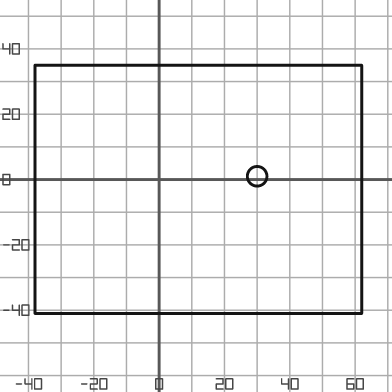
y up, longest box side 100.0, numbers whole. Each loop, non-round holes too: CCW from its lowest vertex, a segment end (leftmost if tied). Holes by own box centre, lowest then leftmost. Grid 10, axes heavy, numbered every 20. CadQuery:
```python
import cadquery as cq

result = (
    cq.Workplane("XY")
    .moveTo(-38.0, -41.0)
    .lineTo(62.0, -41.0)
    .lineTo(62.0, 35.0)
    .lineTo(-38.0, 35.0)
    .close()
    .moveTo(30.0, 1.0)
    .circle(3.0)
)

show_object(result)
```